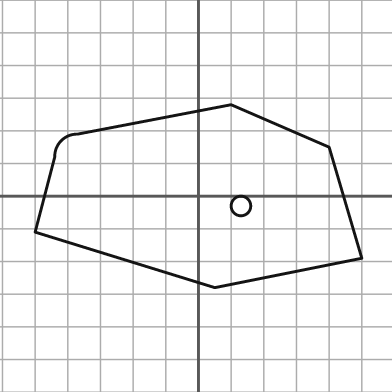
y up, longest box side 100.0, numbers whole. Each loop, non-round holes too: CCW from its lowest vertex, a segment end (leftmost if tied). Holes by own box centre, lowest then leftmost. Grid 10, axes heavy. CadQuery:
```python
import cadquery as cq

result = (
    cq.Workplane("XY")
    .moveTo(5.0, -28.0)
    .lineTo(50.0, -19.0)
    .lineTo(40.0, 15.0)
    .lineTo(10.0, 28.0)
    .lineTo(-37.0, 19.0)
    .threePointArc((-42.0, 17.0), (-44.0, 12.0))
    .lineTo(-50.0, -11.0)
    .close()
    .moveTo(13.0, -3.0)
    .circle(3.0)
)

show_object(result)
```